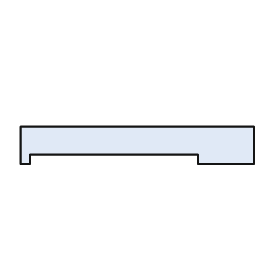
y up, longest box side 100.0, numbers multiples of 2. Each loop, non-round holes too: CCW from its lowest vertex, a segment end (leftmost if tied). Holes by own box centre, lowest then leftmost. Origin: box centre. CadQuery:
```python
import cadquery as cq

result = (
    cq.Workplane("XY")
    .moveTo(-50.0, -8.0)
    .lineTo(-46.0, -8.0)
    .lineTo(-46.0, -4.0)
    .lineTo(26.0, -4.0)
    .lineTo(26.0, -8.0)
    .lineTo(50.0, -8.0)
    .lineTo(50.0, 8.0)
    .lineTo(-50.0, 8.0)
    .close()
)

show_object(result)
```